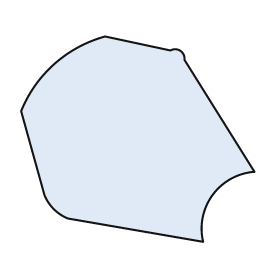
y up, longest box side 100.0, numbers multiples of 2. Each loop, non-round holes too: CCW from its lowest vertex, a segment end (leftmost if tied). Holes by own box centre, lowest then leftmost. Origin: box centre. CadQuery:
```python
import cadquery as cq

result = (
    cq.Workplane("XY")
    .moveTo(28.0, -44.0)
    .threePointArc((32.0, -24.0), (50.0, -14.0))
    .lineTo(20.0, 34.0)
    .threePointArc((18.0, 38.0), (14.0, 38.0))
    .lineTo(-14.0, 44.0)
    .threePointArc((-36.0, 32.0), (-50.0, 12.0))
    .lineTo(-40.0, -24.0)
    .threePointArc((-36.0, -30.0), (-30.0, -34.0))
    .close()
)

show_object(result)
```